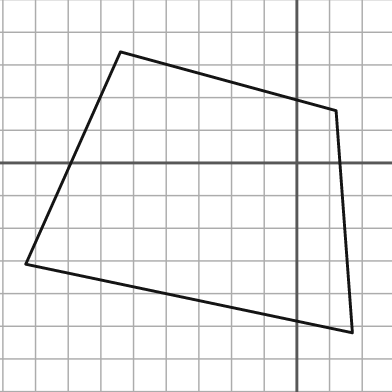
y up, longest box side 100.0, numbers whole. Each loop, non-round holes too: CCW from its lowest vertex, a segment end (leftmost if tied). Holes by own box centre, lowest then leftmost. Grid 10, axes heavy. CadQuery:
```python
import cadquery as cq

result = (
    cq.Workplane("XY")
    .moveTo(17.0, -52.0)
    .lineTo(12.0, 16.0)
    .lineTo(-54.0, 34.0)
    .lineTo(-83.0, -31.0)
    .close()
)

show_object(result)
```